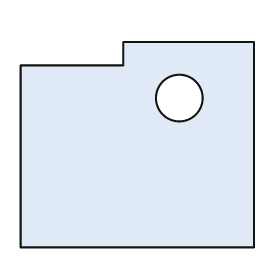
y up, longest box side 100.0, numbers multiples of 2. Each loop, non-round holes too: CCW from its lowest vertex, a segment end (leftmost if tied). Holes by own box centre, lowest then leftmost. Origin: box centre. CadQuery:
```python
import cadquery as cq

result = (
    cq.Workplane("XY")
    .moveTo(-50.0, -44.0)
    .lineTo(50.0, -44.0)
    .lineTo(50.0, 44.0)
    .lineTo(-6.0, 44.0)
    .lineTo(-6.0, 34.0)
    .lineTo(-50.0, 34.0)
    .close()
    .moveTo(18.0, 20.0)
    .circle(10.0)
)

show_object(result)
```